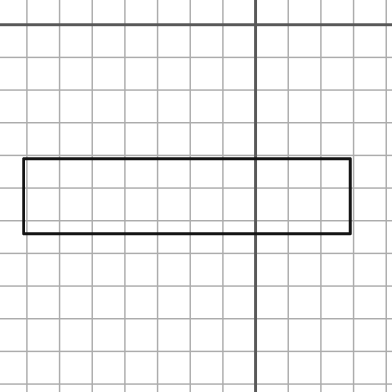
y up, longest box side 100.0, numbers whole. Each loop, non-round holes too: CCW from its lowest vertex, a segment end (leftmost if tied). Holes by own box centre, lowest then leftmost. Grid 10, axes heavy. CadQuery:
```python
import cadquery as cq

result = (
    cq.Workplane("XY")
    .moveTo(-71.0, -64.0)
    .lineTo(29.0, -64.0)
    .lineTo(29.0, -41.0)
    .lineTo(-71.0, -41.0)
    .close()
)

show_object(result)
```